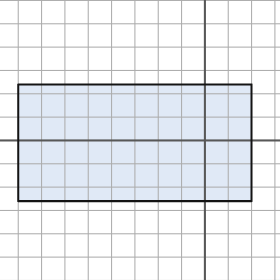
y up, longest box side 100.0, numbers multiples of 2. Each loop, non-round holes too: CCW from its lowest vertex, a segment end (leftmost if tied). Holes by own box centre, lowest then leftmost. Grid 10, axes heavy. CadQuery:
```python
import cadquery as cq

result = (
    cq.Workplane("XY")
    .moveTo(-80.0, -26.0)
    .lineTo(20.0, -26.0)
    .lineTo(20.0, 24.0)
    .lineTo(-80.0, 24.0)
    .close()
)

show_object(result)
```